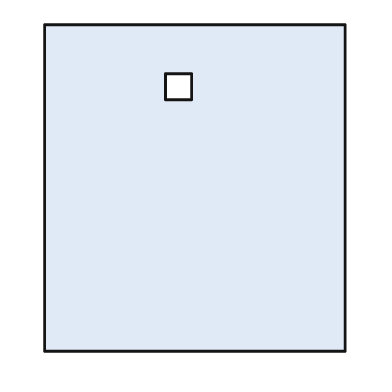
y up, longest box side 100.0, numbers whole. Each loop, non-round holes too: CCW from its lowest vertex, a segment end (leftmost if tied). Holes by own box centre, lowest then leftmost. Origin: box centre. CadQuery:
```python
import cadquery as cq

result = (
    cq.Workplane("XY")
    .moveTo(-46.0, -50.0)
    .lineTo(46.0, -50.0)
    .lineTo(46.0, 50.0)
    .lineTo(-46.0, 50.0)
    .close()
    .moveTo(-9.0, 27.0)
    .lineTo(-1.0, 27.0)
    .lineTo(-1.0, 35.0)
    .lineTo(-9.0, 35.0)
    .close()
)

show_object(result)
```